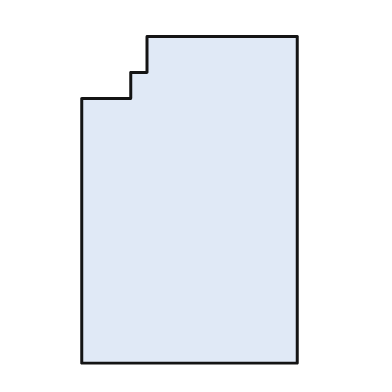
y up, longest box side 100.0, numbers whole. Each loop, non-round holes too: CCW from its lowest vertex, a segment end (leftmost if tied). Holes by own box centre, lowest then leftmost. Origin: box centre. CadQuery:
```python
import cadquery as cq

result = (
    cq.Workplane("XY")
    .moveTo(-33.0, -50.0)
    .lineTo(33.0, -50.0)
    .lineTo(33.0, 50.0)
    .lineTo(-13.0, 50.0)
    .lineTo(-13.0, 39.0)
    .lineTo(-18.0, 39.0)
    .lineTo(-18.0, 31.0)
    .lineTo(-33.0, 31.0)
    .close()
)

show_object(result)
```